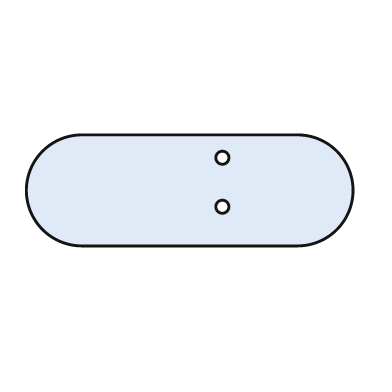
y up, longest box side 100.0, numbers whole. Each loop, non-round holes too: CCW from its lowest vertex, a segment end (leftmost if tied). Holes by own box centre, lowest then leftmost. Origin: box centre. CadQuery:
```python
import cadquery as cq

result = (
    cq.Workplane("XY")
    .moveTo(-33.0, -17.0)
    .lineTo(33.0, -17.0)
    .threePointArc((50.0, 0.0), (33.0, 17.0))
    .lineTo(-33.0, 17.0)
    .threePointArc((-50.0, 0.0), (-33.0, -17.0))
    .close()
    .moveTo(10.0, -5.0)
    .circle(2.0)
    .moveTo(10.0, 10.0)
    .circle(2.0)
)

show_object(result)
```